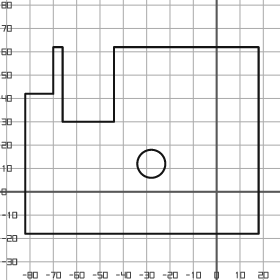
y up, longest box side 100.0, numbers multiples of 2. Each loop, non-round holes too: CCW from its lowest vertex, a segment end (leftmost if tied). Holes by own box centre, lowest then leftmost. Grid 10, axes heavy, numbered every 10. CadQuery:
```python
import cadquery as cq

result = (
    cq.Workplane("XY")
    .moveTo(-82.0, -18.0)
    .lineTo(18.0, -18.0)
    .lineTo(18.0, 62.0)
    .lineTo(-44.0, 62.0)
    .lineTo(-44.0, 30.0)
    .lineTo(-66.0, 30.0)
    .lineTo(-66.0, 62.0)
    .lineTo(-70.0, 62.0)
    .lineTo(-70.0, 42.0)
    .lineTo(-82.0, 42.0)
    .close()
    .moveTo(-28.0, 12.0)
    .circle(6.0)
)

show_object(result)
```